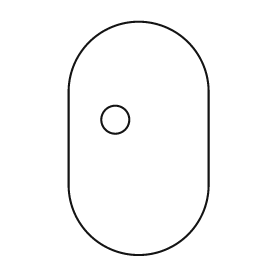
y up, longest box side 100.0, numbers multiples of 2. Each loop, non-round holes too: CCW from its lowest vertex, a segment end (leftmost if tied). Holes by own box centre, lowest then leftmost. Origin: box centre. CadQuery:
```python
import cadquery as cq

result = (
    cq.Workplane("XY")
    .moveTo(-30.0, -20.0)
    .threePointArc((0.0, -50.0), (30.0, -20.0))
    .lineTo(30.0, 20.0)
    .threePointArc((0.0, 50.0), (-30.0, 20.0))
    .close()
    .moveTo(-10.0, 8.0)
    .circle(6.0)
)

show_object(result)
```